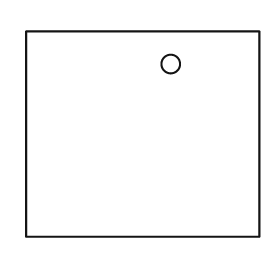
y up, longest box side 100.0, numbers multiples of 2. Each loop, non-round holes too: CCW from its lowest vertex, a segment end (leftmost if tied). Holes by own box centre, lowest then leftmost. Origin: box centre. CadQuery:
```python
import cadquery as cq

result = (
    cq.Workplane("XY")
    .moveTo(-50.0, -44.0)
    .lineTo(50.0, -44.0)
    .lineTo(50.0, 44.0)
    .lineTo(-50.0, 44.0)
    .close()
    .moveTo(12.0, 30.0)
    .circle(4.0)
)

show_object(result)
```